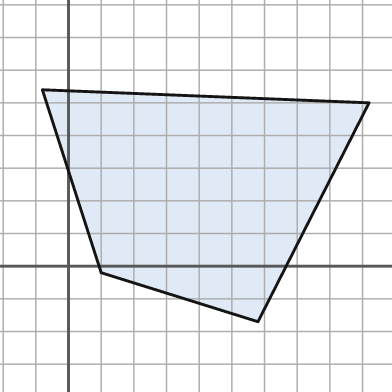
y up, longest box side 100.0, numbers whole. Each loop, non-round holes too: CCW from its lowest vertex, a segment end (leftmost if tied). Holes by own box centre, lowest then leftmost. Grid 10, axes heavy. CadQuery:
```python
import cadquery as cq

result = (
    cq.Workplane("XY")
    .moveTo(58.0, -17.0)
    .lineTo(92.0, 50.0)
    .lineTo(-8.0, 54.0)
    .lineTo(10.0, -2.0)
    .close()
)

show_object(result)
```